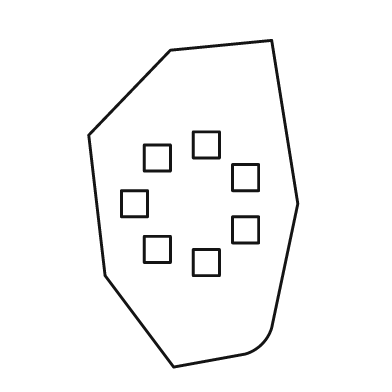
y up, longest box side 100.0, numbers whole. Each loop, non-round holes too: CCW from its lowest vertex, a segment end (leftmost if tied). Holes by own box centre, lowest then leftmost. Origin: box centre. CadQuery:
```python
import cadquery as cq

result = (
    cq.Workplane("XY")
    .moveTo(-6.0, -50.0)
    .lineTo(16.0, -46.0)
    .threePointArc((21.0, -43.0), (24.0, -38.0))
    .lineTo(32.0, 0.0)
    .lineTo(24.0, 50.0)
    .lineTo(-7.0, 47.0)
    .lineTo(-32.0, 21.0)
    .lineTo(-27.0, -22.0)
    .close()
    .moveTo(0.0, -22.0)
    .lineTo(8.0, -22.0)
    .lineTo(8.0, -14.0)
    .lineTo(0.0, -14.0)
    .close()
    .moveTo(-15.0, -18.0)
    .lineTo(-7.0, -18.0)
    .lineTo(-7.0, -10.0)
    .lineTo(-15.0, -10.0)
    .close()
    .moveTo(12.0, -12.0)
    .lineTo(20.0, -12.0)
    .lineTo(20.0, -4.0)
    .lineTo(12.0, -4.0)
    .close()
    .moveTo(-22.0, -4.0)
    .lineTo(-14.0, -4.0)
    .lineTo(-14.0, 4.0)
    .lineTo(-22.0, 4.0)
    .close()
    .moveTo(12.0, 4.0)
    .lineTo(20.0, 4.0)
    .lineTo(20.0, 12.0)
    .lineTo(12.0, 12.0)
    .close()
    .moveTo(-15.0, 10.0)
    .lineTo(-7.0, 10.0)
    .lineTo(-7.0, 18.0)
    .lineTo(-15.0, 18.0)
    .close()
    .moveTo(0.0, 14.0)
    .lineTo(8.0, 14.0)
    .lineTo(8.0, 22.0)
    .lineTo(0.0, 22.0)
    .close()
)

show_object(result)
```